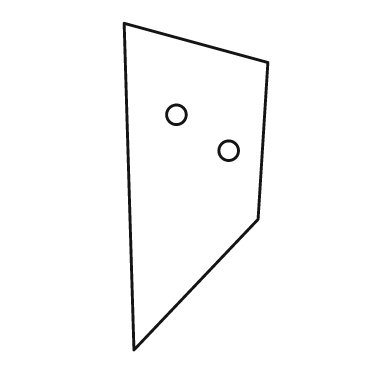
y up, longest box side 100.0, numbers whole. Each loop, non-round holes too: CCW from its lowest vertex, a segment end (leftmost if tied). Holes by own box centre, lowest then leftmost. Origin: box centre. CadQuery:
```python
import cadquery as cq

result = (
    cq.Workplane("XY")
    .moveTo(-19.0, -50.0)
    .lineTo(19.0, -10.0)
    .lineTo(22.0, 38.0)
    .lineTo(-22.0, 50.0)
    .close()
    .moveTo(10.0, 11.0)
    .circle(3.0)
    .moveTo(-6.0, 22.0)
    .circle(3.0)
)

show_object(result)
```